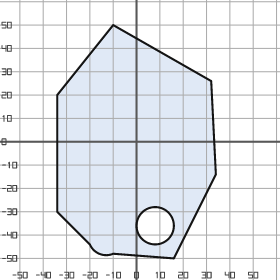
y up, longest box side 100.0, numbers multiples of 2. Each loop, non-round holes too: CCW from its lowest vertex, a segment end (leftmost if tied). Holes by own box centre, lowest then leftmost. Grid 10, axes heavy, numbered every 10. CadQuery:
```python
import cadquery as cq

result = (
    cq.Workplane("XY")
    .moveTo(16.0, -50.0)
    .lineTo(34.0, -14.0)
    .lineTo(32.0, 26.0)
    .lineTo(-10.0, 50.0)
    .lineTo(-34.0, 20.0)
    .lineTo(-34.0, -30.0)
    .lineTo(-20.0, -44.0)
    .threePointArc((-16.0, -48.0), (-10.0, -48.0))
    .close()
    .moveTo(8.0, -36.0)
    .circle(8.0)
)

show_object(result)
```